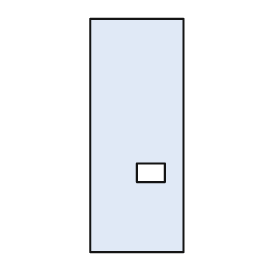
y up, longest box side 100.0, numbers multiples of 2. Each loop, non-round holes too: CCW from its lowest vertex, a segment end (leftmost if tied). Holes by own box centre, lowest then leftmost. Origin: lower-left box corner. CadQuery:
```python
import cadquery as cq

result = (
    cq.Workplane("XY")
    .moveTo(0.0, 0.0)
    .lineTo(40.0, 0.0)
    .lineTo(40.0, 100.0)
    .lineTo(0.0, 100.0)
    .close()
    .moveTo(20.0, 30.0)
    .lineTo(32.0, 30.0)
    .lineTo(32.0, 38.0)
    .lineTo(20.0, 38.0)
    .close()
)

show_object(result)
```